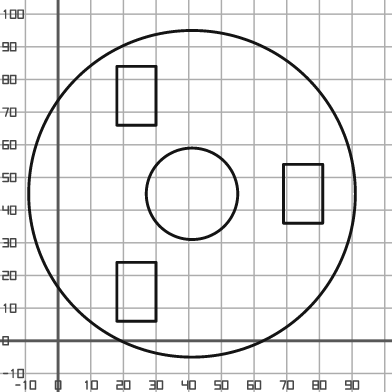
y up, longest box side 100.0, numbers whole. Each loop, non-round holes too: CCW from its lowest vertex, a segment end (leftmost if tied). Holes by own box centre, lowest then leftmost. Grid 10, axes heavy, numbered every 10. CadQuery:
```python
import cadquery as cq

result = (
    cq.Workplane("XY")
    .moveTo(41.0, 45.0)
    .circle(50.0)
    .moveTo(18.0, 6.0)
    .lineTo(30.0, 6.0)
    .lineTo(30.0, 24.0)
    .lineTo(18.0, 24.0)
    .close()
    .moveTo(41.0, 45.0)
    .circle(14.0)
    .moveTo(69.0, 36.0)
    .lineTo(81.0, 36.0)
    .lineTo(81.0, 54.0)
    .lineTo(69.0, 54.0)
    .close()
    .moveTo(18.0, 66.0)
    .lineTo(30.0, 66.0)
    .lineTo(30.0, 84.0)
    .lineTo(18.0, 84.0)
    .close()
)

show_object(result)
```